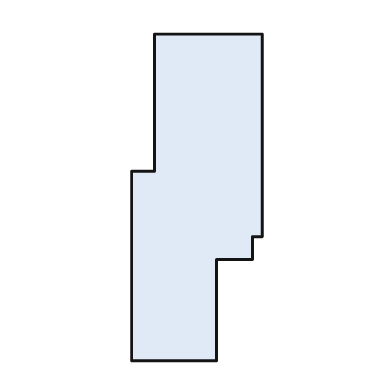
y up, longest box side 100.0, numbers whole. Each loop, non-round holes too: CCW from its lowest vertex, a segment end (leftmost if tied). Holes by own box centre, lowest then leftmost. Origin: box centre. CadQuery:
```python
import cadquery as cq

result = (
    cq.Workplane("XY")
    .moveTo(-20.0, -50.0)
    .lineTo(6.0, -50.0)
    .lineTo(6.0, -19.0)
    .lineTo(17.0, -19.0)
    .lineTo(17.0, -12.0)
    .lineTo(20.0, -12.0)
    .lineTo(20.0, 50.0)
    .lineTo(-13.0, 50.0)
    .lineTo(-13.0, 8.0)
    .lineTo(-20.0, 8.0)
    .close()
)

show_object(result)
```